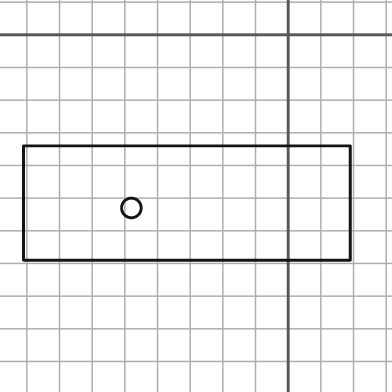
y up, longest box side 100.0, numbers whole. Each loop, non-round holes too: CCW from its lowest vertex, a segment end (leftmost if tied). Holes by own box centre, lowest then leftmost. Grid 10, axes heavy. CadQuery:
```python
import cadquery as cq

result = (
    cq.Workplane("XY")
    .moveTo(-81.0, -69.0)
    .lineTo(19.0, -69.0)
    .lineTo(19.0, -34.0)
    .lineTo(-81.0, -34.0)
    .close()
    .moveTo(-48.0, -53.0)
    .circle(3.0)
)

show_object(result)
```